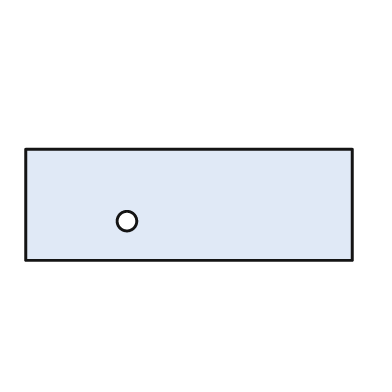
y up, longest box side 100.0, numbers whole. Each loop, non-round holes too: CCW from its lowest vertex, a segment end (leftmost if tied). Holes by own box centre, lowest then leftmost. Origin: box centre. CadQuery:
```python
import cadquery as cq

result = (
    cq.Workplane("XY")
    .moveTo(-50.0, -17.0)
    .lineTo(50.0, -17.0)
    .lineTo(50.0, 17.0)
    .lineTo(-50.0, 17.0)
    .close()
    .moveTo(-19.0, -5.0)
    .circle(3.0)
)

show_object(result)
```